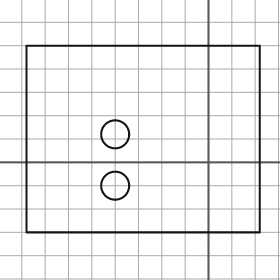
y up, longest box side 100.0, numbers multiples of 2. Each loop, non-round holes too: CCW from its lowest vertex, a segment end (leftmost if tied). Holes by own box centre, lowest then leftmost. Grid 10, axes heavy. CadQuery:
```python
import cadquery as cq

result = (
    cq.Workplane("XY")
    .moveTo(-78.0, -30.0)
    .lineTo(22.0, -30.0)
    .lineTo(22.0, 50.0)
    .lineTo(-78.0, 50.0)
    .close()
    .moveTo(-40.0, -10.0)
    .circle(6.0)
    .moveTo(-40.0, 12.0)
    .circle(6.0)
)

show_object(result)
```